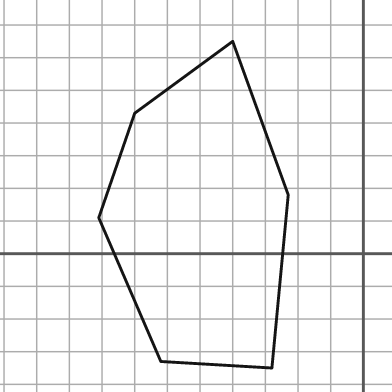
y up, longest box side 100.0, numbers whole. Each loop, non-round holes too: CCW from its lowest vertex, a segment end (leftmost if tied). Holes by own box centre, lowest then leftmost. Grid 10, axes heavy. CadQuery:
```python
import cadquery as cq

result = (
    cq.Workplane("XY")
    .moveTo(-28.0, -35.0)
    .lineTo(-23.0, 18.0)
    .lineTo(-40.0, 65.0)
    .lineTo(-70.0, 43.0)
    .lineTo(-81.0, 11.0)
    .lineTo(-62.0, -33.0)
    .close()
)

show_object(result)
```